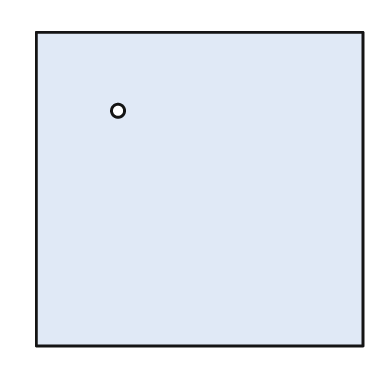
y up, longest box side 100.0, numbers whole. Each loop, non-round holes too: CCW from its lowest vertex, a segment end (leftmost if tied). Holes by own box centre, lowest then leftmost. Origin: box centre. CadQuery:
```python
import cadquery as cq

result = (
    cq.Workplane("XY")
    .moveTo(-50.0, -48.0)
    .lineTo(50.0, -48.0)
    .lineTo(50.0, 48.0)
    .lineTo(-50.0, 48.0)
    .close()
    .moveTo(-25.0, 24.0)
    .circle(2.0)
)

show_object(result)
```